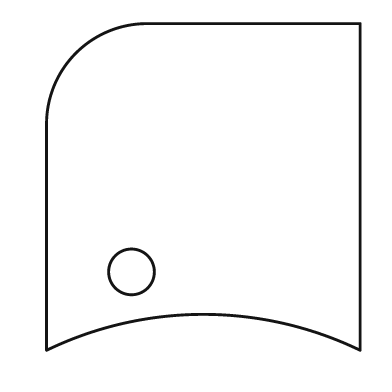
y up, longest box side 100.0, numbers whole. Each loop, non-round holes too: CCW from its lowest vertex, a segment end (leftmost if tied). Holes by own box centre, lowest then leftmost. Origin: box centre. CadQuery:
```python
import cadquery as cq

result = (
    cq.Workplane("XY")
    .moveTo(-48.0, -50.0)
    .threePointArc((0.0, -39.0), (48.0, -50.0))
    .lineTo(48.0, 50.0)
    .lineTo(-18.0, 50.0)
    .threePointArc((-39.0, 41.0), (-48.0, 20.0))
    .close()
    .moveTo(-22.0, -26.0)
    .circle(7.0)
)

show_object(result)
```